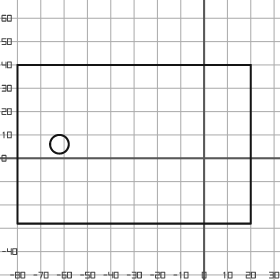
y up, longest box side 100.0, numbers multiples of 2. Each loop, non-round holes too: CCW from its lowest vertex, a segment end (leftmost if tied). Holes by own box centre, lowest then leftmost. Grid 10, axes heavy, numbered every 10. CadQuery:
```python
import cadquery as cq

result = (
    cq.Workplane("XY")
    .moveTo(-80.0, -28.0)
    .lineTo(20.0, -28.0)
    .lineTo(20.0, 40.0)
    .lineTo(-80.0, 40.0)
    .close()
    .moveTo(-62.0, 6.0)
    .circle(4.0)
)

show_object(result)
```